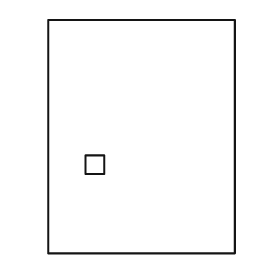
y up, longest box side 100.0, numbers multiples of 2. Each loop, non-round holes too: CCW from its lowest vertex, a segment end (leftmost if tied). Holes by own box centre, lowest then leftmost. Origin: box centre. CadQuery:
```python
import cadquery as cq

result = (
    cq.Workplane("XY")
    .moveTo(-40.0, -50.0)
    .lineTo(40.0, -50.0)
    .lineTo(40.0, 50.0)
    .lineTo(-40.0, 50.0)
    .close()
    .moveTo(-24.0, -16.0)
    .lineTo(-16.0, -16.0)
    .lineTo(-16.0, -8.0)
    .lineTo(-24.0, -8.0)
    .close()
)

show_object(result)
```